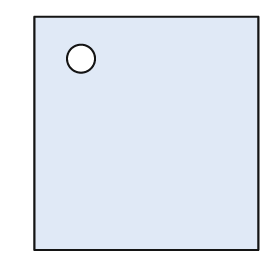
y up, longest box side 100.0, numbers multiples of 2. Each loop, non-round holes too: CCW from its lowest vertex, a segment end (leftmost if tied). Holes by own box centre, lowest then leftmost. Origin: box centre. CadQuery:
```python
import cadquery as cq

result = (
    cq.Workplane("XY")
    .moveTo(-48.0, -50.0)
    .lineTo(48.0, -50.0)
    .lineTo(48.0, 50.0)
    .lineTo(-48.0, 50.0)
    .close()
    .moveTo(-28.0, 32.0)
    .circle(6.0)
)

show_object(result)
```